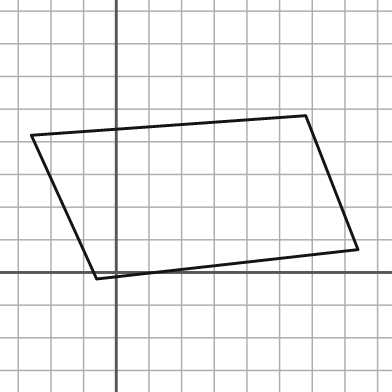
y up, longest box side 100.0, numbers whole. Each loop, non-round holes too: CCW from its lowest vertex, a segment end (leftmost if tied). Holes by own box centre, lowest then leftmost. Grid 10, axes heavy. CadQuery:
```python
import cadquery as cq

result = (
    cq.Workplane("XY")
    .moveTo(-6.0, -2.0)
    .lineTo(74.0, 7.0)
    .lineTo(58.0, 48.0)
    .lineTo(-26.0, 42.0)
    .close()
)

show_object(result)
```